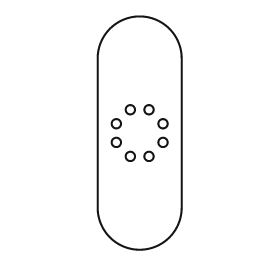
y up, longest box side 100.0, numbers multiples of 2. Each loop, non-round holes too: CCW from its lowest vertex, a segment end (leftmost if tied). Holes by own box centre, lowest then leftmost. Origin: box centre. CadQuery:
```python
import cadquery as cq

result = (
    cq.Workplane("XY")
    .moveTo(-18.0, -32.0)
    .threePointArc((0.0, -50.0), (18.0, -32.0))
    .lineTo(18.0, 32.0)
    .threePointArc((0.0, 50.0), (-18.0, 32.0))
    .close()
    .moveTo(-4.0, -10.0)
    .circle(2.0)
    .moveTo(4.0, -10.0)
    .circle(2.0)
    .moveTo(-10.0, -4.0)
    .circle(2.0)
    .moveTo(10.0, -4.0)
    .circle(2.0)
    .moveTo(-10.0, 4.0)
    .circle(2.0)
    .moveTo(10.0, 4.0)
    .circle(2.0)
    .moveTo(-4.0, 10.0)
    .circle(2.0)
    .moveTo(4.0, 10.0)
    .circle(2.0)
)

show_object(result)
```